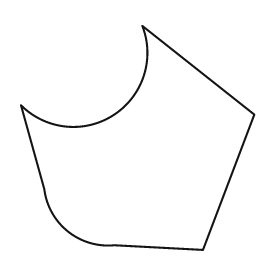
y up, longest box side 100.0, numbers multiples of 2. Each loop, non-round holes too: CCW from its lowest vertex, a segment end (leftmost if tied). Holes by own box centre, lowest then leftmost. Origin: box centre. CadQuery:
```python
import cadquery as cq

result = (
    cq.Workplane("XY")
    .moveTo(28.0, -48.0)
    .lineTo(50.0, 10.0)
    .lineTo(2.0, 48.0)
    .threePointArc((-10.0, 10.0), (-50.0, 14.0))
    .lineTo(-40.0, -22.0)
    .threePointArc((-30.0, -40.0), (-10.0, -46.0))
    .close()
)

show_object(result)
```